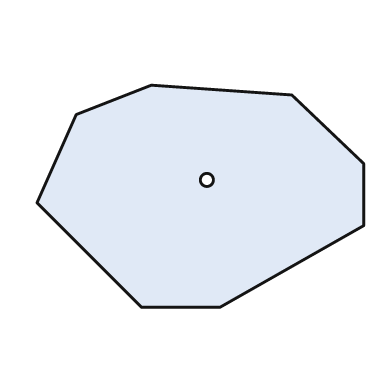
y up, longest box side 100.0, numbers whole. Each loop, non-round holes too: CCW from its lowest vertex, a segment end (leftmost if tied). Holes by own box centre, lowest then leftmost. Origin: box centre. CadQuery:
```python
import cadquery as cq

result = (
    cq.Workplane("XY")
    .moveTo(-18.0, -34.0)
    .lineTo(6.0, -34.0)
    .lineTo(50.0, -9.0)
    .lineTo(50.0, 10.0)
    .lineTo(28.0, 31.0)
    .lineTo(-15.0, 34.0)
    .lineTo(-38.0, 25.0)
    .lineTo(-50.0, -2.0)
    .close()
    .moveTo(2.0, 5.0)
    .circle(2.0)
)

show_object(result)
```